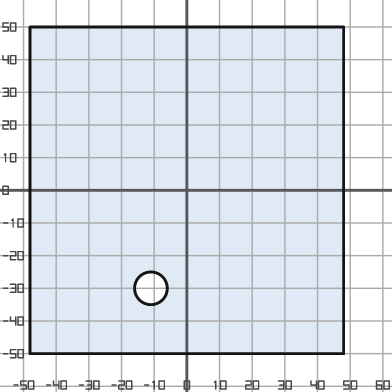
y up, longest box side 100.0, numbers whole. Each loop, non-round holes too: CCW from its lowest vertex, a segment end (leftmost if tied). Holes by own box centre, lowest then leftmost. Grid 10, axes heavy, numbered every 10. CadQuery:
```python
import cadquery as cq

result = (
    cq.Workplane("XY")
    .moveTo(-48.0, -50.0)
    .lineTo(48.0, -50.0)
    .lineTo(48.0, 50.0)
    .lineTo(-48.0, 50.0)
    .close()
    .moveTo(-11.0, -30.0)
    .circle(5.0)
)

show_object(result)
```